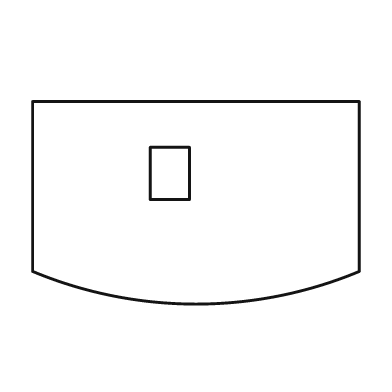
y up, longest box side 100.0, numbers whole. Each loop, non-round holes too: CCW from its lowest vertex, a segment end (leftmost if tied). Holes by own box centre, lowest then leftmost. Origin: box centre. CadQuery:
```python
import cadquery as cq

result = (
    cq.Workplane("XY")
    .moveTo(-50.0, -21.0)
    .threePointArc((0.0, -31.0), (50.0, -21.0))
    .lineTo(50.0, 31.0)
    .lineTo(-50.0, 31.0)
    .close()
    .moveTo(-14.0, 1.0)
    .lineTo(-2.0, 1.0)
    .lineTo(-2.0, 17.0)
    .lineTo(-14.0, 17.0)
    .close()
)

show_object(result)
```